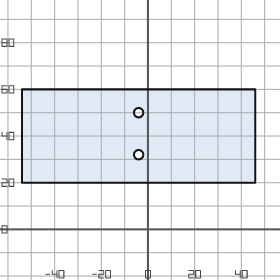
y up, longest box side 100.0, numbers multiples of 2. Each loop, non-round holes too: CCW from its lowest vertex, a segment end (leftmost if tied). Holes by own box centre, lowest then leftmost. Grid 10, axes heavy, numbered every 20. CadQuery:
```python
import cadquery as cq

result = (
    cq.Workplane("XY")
    .moveTo(-54.0, 20.0)
    .lineTo(46.0, 20.0)
    .lineTo(46.0, 60.0)
    .lineTo(-54.0, 60.0)
    .close()
    .moveTo(-4.0, 32.0)
    .circle(2.0)
    .moveTo(-4.0, 50.0)
    .circle(2.0)
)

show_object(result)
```